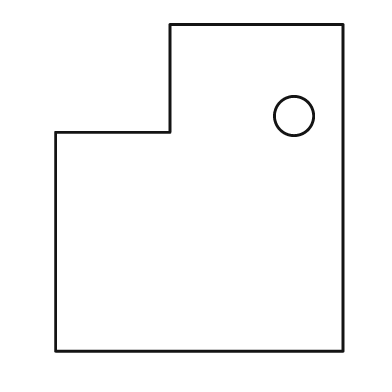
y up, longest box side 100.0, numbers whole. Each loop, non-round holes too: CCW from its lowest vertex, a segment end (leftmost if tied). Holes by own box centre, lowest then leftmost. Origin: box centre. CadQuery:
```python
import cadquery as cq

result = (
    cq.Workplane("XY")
    .moveTo(-44.0, -50.0)
    .lineTo(44.0, -50.0)
    .lineTo(44.0, 50.0)
    .lineTo(-9.0, 50.0)
    .lineTo(-9.0, 17.0)
    .lineTo(-44.0, 17.0)
    .close()
    .moveTo(29.0, 22.0)
    .circle(6.0)
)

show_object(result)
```